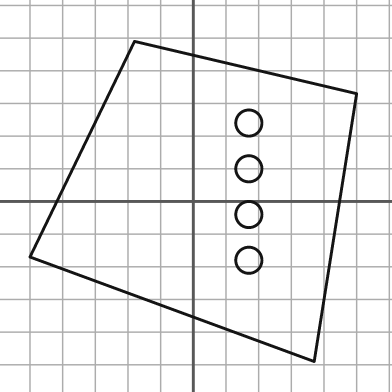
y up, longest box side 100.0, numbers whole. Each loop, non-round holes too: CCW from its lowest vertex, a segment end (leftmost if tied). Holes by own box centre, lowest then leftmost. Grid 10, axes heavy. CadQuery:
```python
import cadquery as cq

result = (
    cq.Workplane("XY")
    .moveTo(37.0, -49.0)
    .lineTo(50.0, 33.0)
    .lineTo(-18.0, 49.0)
    .lineTo(-50.0, -17.0)
    .close()
    .moveTo(17.0, -18.0)
    .circle(4.0)
    .moveTo(17.0, -4.0)
    .circle(4.0)
    .moveTo(17.0, 10.0)
    .circle(4.0)
    .moveTo(17.0, 24.0)
    .circle(4.0)
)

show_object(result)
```